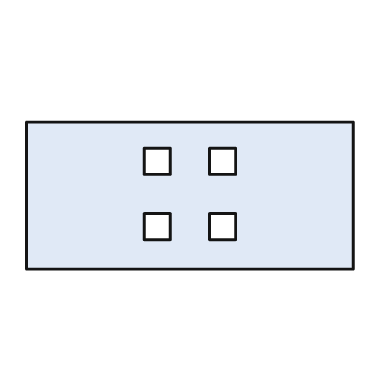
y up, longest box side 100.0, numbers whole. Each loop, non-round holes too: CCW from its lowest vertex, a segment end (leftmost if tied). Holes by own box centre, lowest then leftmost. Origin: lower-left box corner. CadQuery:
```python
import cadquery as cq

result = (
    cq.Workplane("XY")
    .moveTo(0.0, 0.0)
    .lineTo(100.0, 0.0)
    .lineTo(100.0, 45.0)
    .lineTo(0.0, 45.0)
    .close()
    .moveTo(36.0, 9.0)
    .lineTo(44.0, 9.0)
    .lineTo(44.0, 17.0)
    .lineTo(36.0, 17.0)
    .close()
    .moveTo(56.0, 9.0)
    .lineTo(64.0, 9.0)
    .lineTo(64.0, 17.0)
    .lineTo(56.0, 17.0)
    .close()
    .moveTo(36.0, 29.0)
    .lineTo(44.0, 29.0)
    .lineTo(44.0, 37.0)
    .lineTo(36.0, 37.0)
    .close()
    .moveTo(56.0, 29.0)
    .lineTo(64.0, 29.0)
    .lineTo(64.0, 37.0)
    .lineTo(56.0, 37.0)
    .close()
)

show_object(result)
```